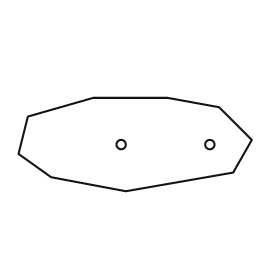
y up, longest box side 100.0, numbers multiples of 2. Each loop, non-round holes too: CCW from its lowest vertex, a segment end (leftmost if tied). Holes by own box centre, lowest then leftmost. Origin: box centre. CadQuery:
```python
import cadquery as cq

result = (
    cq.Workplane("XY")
    .moveTo(-4.0, -20.0)
    .lineTo(42.0, -12.0)
    .lineTo(50.0, 2.0)
    .lineTo(36.0, 16.0)
    .lineTo(14.0, 20.0)
    .lineTo(-18.0, 20.0)
    .lineTo(-46.0, 12.0)
    .lineTo(-50.0, -4.0)
    .lineTo(-36.0, -14.0)
    .close()
    .moveTo(-6.0, 0.0)
    .circle(2.0)
    .moveTo(32.0, 0.0)
    .circle(2.0)
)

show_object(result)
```